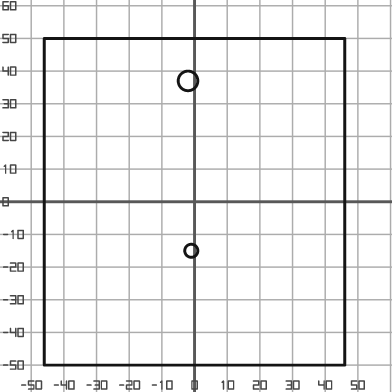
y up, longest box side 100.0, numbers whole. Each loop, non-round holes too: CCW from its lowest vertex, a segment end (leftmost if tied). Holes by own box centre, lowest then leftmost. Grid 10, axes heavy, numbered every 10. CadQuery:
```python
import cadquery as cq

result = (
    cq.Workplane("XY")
    .moveTo(-46.0, -50.0)
    .lineTo(46.0, -50.0)
    .lineTo(46.0, 50.0)
    .lineTo(-46.0, 50.0)
    .close()
    .moveTo(-1.0, -15.0)
    .circle(2.0)
    .moveTo(-2.0, 37.0)
    .circle(3.0)
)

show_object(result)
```